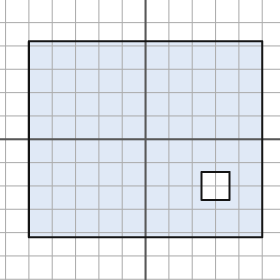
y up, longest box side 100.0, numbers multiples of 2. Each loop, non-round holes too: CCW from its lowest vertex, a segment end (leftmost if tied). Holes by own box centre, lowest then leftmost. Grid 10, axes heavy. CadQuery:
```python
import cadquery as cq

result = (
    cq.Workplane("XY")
    .moveTo(-50.0, -42.0)
    .lineTo(50.0, -42.0)
    .lineTo(50.0, 42.0)
    .lineTo(-50.0, 42.0)
    .close()
    .moveTo(24.0, -26.0)
    .lineTo(36.0, -26.0)
    .lineTo(36.0, -14.0)
    .lineTo(24.0, -14.0)
    .close()
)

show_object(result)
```